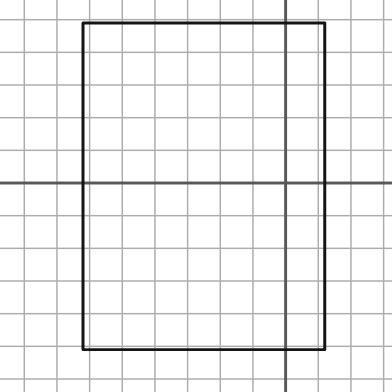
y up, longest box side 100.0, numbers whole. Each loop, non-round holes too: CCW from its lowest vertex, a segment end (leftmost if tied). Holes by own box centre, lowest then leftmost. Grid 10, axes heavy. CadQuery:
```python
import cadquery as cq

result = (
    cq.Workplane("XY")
    .moveTo(-62.0, -51.0)
    .lineTo(12.0, -51.0)
    .lineTo(12.0, 49.0)
    .lineTo(-62.0, 49.0)
    .close()
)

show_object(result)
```